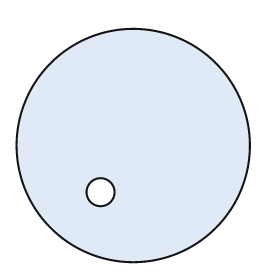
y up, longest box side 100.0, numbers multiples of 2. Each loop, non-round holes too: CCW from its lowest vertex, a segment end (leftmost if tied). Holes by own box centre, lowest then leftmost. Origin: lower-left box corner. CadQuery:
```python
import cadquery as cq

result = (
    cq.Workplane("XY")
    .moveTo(50.0, 50.0)
    .circle(50.0)
    .moveTo(36.0, 30.0)
    .circle(6.0)
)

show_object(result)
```